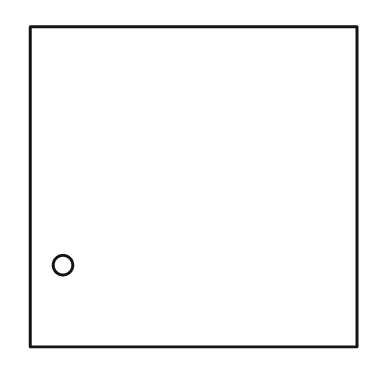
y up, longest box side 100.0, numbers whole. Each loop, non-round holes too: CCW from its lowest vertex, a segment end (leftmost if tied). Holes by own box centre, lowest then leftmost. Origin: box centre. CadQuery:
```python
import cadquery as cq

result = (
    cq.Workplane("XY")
    .moveTo(-50.0, -49.0)
    .lineTo(50.0, -49.0)
    .lineTo(50.0, 49.0)
    .lineTo(-50.0, 49.0)
    .close()
    .moveTo(-40.0, -24.0)
    .circle(3.0)
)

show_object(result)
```